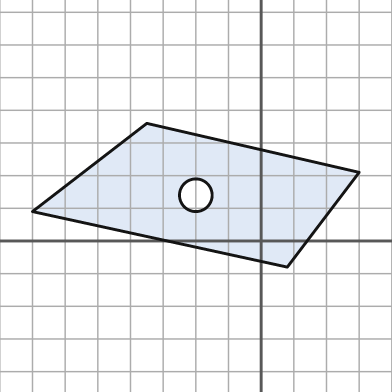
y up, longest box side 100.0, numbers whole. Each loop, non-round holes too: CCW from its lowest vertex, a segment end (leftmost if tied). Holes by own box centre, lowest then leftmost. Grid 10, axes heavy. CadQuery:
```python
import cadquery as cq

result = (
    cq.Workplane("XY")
    .moveTo(8.0, -8.0)
    .lineTo(30.0, 21.0)
    .lineTo(-35.0, 36.0)
    .lineTo(-70.0, 9.0)
    .close()
    .moveTo(-20.0, 14.0)
    .circle(5.0)
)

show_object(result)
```